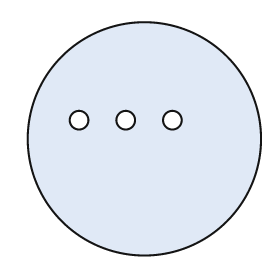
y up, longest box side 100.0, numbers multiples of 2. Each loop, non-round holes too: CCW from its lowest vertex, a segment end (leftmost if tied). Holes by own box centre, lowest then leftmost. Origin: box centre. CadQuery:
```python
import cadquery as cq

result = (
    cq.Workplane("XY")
    .moveTo(0.0, 0.0)
    .circle(50.0)
    .moveTo(-28.0, 8.0)
    .circle(4.0)
    .moveTo(-8.0, 8.0)
    .circle(4.0)
    .moveTo(12.0, 8.0)
    .circle(4.0)
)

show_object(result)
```